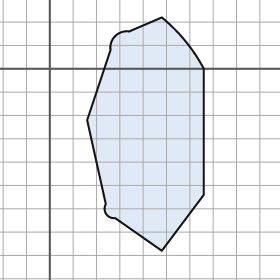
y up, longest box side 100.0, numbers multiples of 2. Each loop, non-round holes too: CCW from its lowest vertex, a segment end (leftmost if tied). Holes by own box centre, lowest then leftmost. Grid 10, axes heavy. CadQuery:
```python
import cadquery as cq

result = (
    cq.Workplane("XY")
    .moveTo(48.0, -78.0)
    .lineTo(66.0, -54.0)
    .lineTo(66.0, 0.0)
    .threePointArc((58.0, 12.0), (48.0, 22.0))
    .lineTo(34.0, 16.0)
    .threePointArc((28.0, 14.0), (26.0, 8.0))
    .lineTo(16.0, -22.0)
    .lineTo(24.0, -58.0)
    .threePointArc((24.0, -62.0), (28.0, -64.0))
    .close()
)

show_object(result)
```